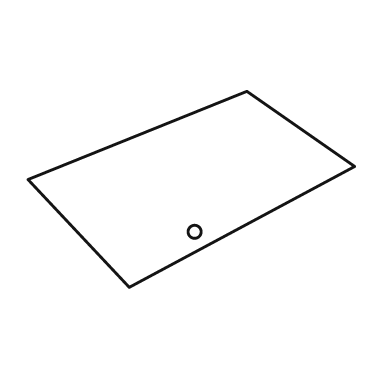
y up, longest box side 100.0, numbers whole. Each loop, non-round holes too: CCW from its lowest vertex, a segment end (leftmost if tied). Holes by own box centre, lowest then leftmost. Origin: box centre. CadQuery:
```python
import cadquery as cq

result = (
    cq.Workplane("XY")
    .moveTo(-19.0, -30.0)
    .lineTo(50.0, 7.0)
    .lineTo(17.0, 30.0)
    .lineTo(-50.0, 3.0)
    .close()
    .moveTo(1.0, -13.0)
    .circle(2.0)
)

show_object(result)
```